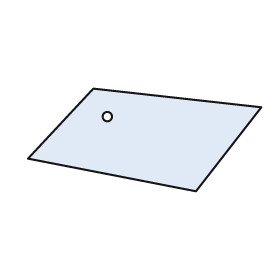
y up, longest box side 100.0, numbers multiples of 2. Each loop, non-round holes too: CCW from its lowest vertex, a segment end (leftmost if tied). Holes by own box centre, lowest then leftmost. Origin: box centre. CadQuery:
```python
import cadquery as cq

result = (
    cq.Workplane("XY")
    .moveTo(22.0, -22.0)
    .lineTo(50.0, 14.0)
    .lineTo(-22.0, 22.0)
    .lineTo(-50.0, -8.0)
    .close()
    .moveTo(-16.0, 10.0)
    .circle(2.0)
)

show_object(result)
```